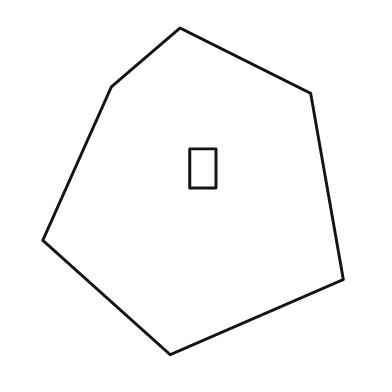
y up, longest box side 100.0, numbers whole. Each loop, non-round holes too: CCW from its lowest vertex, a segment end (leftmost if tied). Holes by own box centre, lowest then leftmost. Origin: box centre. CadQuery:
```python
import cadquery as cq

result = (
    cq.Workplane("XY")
    .moveTo(-7.0, -50.0)
    .lineTo(46.0, -27.0)
    .lineTo(36.0, 30.0)
    .lineTo(-4.0, 50.0)
    .lineTo(-25.0, 32.0)
    .lineTo(-46.0, -15.0)
    .close()
    .moveTo(-1.0, 1.0)
    .lineTo(7.0, 1.0)
    .lineTo(7.0, 13.0)
    .lineTo(-1.0, 13.0)
    .close()
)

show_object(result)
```